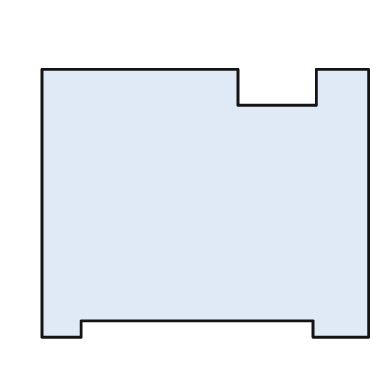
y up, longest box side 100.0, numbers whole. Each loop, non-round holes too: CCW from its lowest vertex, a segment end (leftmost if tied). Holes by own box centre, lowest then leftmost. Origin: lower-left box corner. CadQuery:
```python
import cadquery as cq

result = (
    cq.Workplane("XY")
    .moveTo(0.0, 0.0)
    .lineTo(12.0, 0.0)
    .lineTo(12.0, 5.0)
    .lineTo(83.0, 5.0)
    .lineTo(83.0, 0.0)
    .lineTo(100.0, 0.0)
    .lineTo(100.0, 82.0)
    .lineTo(84.0, 82.0)
    .lineTo(84.0, 71.0)
    .lineTo(60.0, 71.0)
    .lineTo(60.0, 82.0)
    .lineTo(0.0, 82.0)
    .close()
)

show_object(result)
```